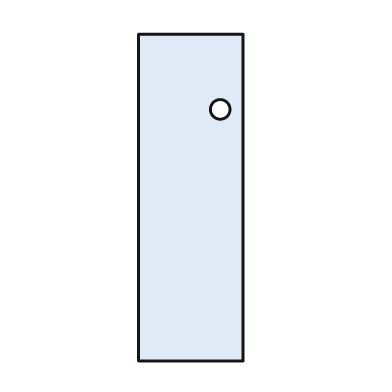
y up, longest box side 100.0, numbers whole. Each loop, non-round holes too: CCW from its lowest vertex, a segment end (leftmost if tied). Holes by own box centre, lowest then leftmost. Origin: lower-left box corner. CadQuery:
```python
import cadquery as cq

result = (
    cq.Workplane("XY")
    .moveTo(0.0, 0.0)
    .lineTo(32.0, 0.0)
    .lineTo(32.0, 100.0)
    .lineTo(0.0, 100.0)
    .close()
    .moveTo(25.0, 77.0)
    .circle(3.0)
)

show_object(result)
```